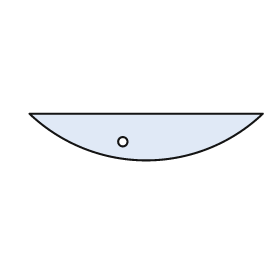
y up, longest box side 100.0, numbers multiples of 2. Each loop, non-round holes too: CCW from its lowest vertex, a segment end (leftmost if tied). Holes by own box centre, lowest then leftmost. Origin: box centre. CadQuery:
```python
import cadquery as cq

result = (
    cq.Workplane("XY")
    .moveTo(-50.0, 10.0)
    .threePointArc((0.0, -10.0), (50.0, 10.0))
    .close()
    .moveTo(-10.0, -2.0)
    .circle(2.0)
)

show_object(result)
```